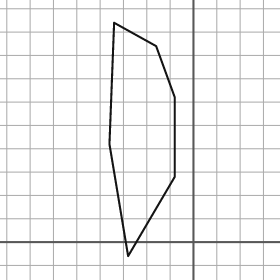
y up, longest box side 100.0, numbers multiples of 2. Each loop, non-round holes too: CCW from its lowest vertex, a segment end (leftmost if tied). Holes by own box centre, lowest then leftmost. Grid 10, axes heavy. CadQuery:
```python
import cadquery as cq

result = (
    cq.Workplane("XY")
    .moveTo(-28.0, -6.0)
    .lineTo(-8.0, 28.0)
    .lineTo(-8.0, 62.0)
    .lineTo(-16.0, 84.0)
    .lineTo(-34.0, 94.0)
    .lineTo(-36.0, 42.0)
    .close()
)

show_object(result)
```